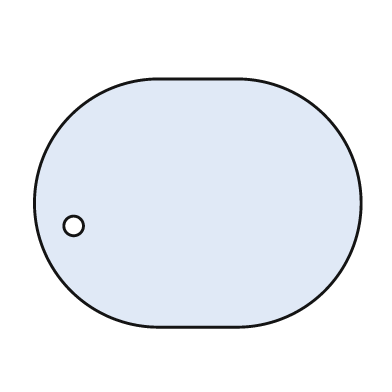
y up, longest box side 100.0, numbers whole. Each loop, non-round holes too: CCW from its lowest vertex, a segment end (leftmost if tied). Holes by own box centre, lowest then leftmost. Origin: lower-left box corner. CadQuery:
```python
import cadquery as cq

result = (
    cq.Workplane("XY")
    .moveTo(38.0, 0.0)
    .lineTo(62.0, 0.0)
    .threePointArc((100.0, 38.0), (62.0, 76.0))
    .lineTo(38.0, 76.0)
    .threePointArc((0.0, 38.0), (38.0, 0.0))
    .close()
    .moveTo(12.0, 31.0)
    .circle(3.0)
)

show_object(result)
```